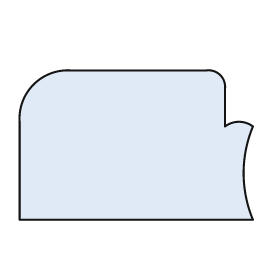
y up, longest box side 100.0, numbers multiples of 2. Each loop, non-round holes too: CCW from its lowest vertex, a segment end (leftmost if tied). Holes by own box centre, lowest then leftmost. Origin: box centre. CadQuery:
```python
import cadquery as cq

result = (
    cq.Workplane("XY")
    .moveTo(-50.0, -32.0)
    .lineTo(50.0, -32.0)
    .threePointArc((46.0, -12.0), (50.0, 8.0))
    .threePointArc((44.0, 10.0), (38.0, 8.0))
    .lineTo(38.0, 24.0)
    .threePointArc((36.0, 30.0), (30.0, 32.0))
    .lineTo(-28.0, 32.0)
    .threePointArc((-44.0, 26.0), (-50.0, 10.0))
    .close()
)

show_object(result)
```